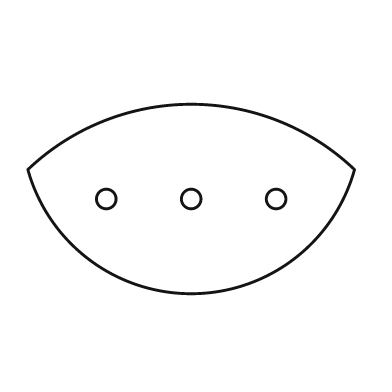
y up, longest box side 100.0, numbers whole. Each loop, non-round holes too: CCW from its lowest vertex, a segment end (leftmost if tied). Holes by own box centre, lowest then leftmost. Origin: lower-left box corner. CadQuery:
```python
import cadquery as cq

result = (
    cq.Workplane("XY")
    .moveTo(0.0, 38.0)
    .threePointArc((50.0, 0.0), (100.0, 38.0))
    .threePointArc((50.0, 58.0), (0.0, 38.0))
    .close()
    .moveTo(24.0, 29.0)
    .circle(3.0)
    .moveTo(50.0, 29.0)
    .circle(3.0)
    .moveTo(76.0, 29.0)
    .circle(3.0)
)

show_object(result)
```